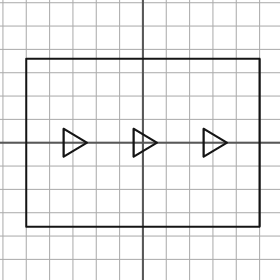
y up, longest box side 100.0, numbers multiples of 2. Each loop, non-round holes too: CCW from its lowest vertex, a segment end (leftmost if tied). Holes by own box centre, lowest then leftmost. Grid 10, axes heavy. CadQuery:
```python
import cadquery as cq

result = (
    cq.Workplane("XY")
    .moveTo(-50.0, -36.0)
    .lineTo(50.0, -36.0)
    .lineTo(50.0, 36.0)
    .lineTo(-50.0, 36.0)
    .close()
    .moveTo(-34.0, -6.0)
    .lineTo(-24.0, 0.0)
    .lineTo(-34.0, 6.0)
    .close()
    .moveTo(-4.0, -6.0)
    .lineTo(6.0, 0.0)
    .lineTo(-4.0, 6.0)
    .close()
    .moveTo(26.0, -6.0)
    .lineTo(36.0, 0.0)
    .lineTo(26.0, 6.0)
    .close()
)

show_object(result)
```